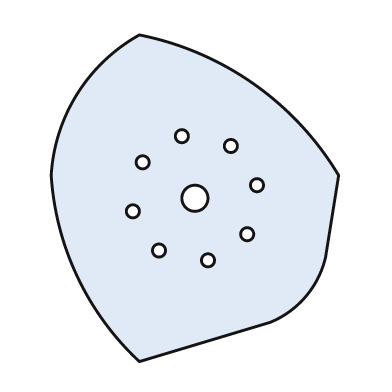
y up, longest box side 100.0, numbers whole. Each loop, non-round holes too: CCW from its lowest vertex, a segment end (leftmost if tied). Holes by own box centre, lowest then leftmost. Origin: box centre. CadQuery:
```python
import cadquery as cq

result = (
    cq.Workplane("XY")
    .moveTo(-17.0, -50.0)
    .lineTo(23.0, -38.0)
    .threePointArc((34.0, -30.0), (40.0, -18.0))
    .lineTo(44.0, 7.0)
    .threePointArc((18.0, 35.0), (-17.0, 50.0))
    .threePointArc((-36.0, 32.0), (-44.0, 7.0))
    .threePointArc((-36.0, -24.0), (-17.0, -50.0))
    .close()
    .moveTo(4.0, -19.0)
    .circle(2.0)
    .moveTo(-11.0, -16.0)
    .circle(2.0)
    .moveTo(16.0, -11.0)
    .circle(2.0)
    .moveTo(-19.0, -4.0)
    .circle(2.0)
    .moveTo(0.0, 0.0)
    .circle(4.0)
    .moveTo(19.0, 4.0)
    .circle(2.0)
    .moveTo(-16.0, 11.0)
    .circle(2.0)
    .moveTo(11.0, 16.0)
    .circle(2.0)
    .moveTo(-4.0, 19.0)
    .circle(2.0)
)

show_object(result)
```